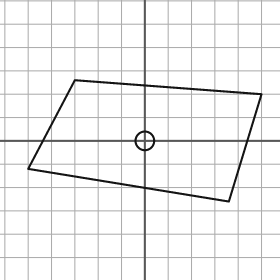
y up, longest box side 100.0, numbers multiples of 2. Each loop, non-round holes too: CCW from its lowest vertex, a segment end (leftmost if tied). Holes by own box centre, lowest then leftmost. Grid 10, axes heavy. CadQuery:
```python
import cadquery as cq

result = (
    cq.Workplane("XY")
    .moveTo(36.0, -26.0)
    .lineTo(50.0, 20.0)
    .lineTo(-30.0, 26.0)
    .lineTo(-50.0, -12.0)
    .close()
    .moveTo(0.0, 0.0)
    .circle(4.0)
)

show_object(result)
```